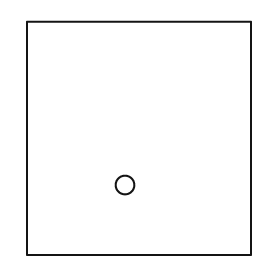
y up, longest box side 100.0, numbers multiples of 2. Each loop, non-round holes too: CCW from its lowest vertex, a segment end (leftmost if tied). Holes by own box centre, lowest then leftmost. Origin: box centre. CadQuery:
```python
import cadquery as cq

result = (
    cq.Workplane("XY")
    .moveTo(-48.0, -50.0)
    .lineTo(48.0, -50.0)
    .lineTo(48.0, 50.0)
    .lineTo(-48.0, 50.0)
    .close()
    .moveTo(-6.0, -20.0)
    .circle(4.0)
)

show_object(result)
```